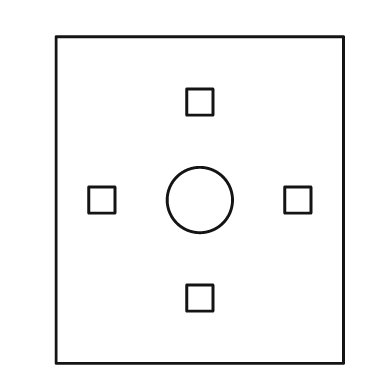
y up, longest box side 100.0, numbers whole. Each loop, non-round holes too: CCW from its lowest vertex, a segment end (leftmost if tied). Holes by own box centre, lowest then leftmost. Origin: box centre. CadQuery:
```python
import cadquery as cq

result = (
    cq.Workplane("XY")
    .moveTo(-44.0, -50.0)
    .lineTo(44.0, -50.0)
    .lineTo(44.0, 50.0)
    .lineTo(-44.0, 50.0)
    .close()
    .moveTo(-4.0, -34.0)
    .lineTo(4.0, -34.0)
    .lineTo(4.0, -26.0)
    .lineTo(-4.0, -26.0)
    .close()
    .moveTo(-34.0, -4.0)
    .lineTo(-26.0, -4.0)
    .lineTo(-26.0, 4.0)
    .lineTo(-34.0, 4.0)
    .close()
    .moveTo(0.0, 0.0)
    .circle(10.0)
    .moveTo(26.0, -4.0)
    .lineTo(34.0, -4.0)
    .lineTo(34.0, 4.0)
    .lineTo(26.0, 4.0)
    .close()
    .moveTo(-4.0, 26.0)
    .lineTo(4.0, 26.0)
    .lineTo(4.0, 34.0)
    .lineTo(-4.0, 34.0)
    .close()
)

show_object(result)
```